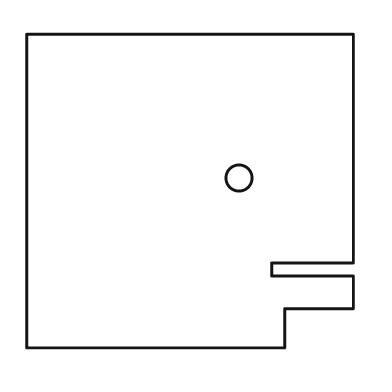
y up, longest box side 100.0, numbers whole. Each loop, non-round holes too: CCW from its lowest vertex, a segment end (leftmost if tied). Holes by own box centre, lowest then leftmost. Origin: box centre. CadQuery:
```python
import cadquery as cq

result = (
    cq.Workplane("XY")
    .moveTo(-50.0, -48.0)
    .lineTo(29.0, -48.0)
    .lineTo(29.0, -36.0)
    .lineTo(50.0, -36.0)
    .lineTo(50.0, -26.0)
    .lineTo(25.0, -26.0)
    .lineTo(25.0, -22.0)
    .lineTo(50.0, -22.0)
    .lineTo(50.0, 48.0)
    .lineTo(-50.0, 48.0)
    .close()
    .moveTo(15.0, 4.0)
    .circle(4.0)
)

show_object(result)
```